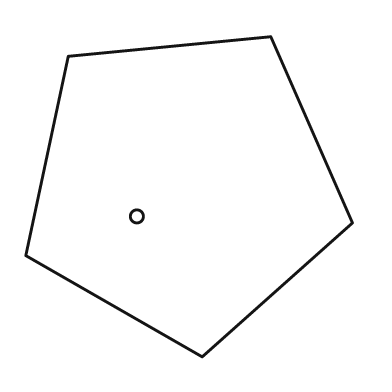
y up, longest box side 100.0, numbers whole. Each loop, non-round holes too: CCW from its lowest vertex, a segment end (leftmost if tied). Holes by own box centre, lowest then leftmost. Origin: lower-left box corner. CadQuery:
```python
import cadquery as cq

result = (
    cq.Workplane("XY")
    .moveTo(54.0, 0.0)
    .lineTo(100.0, 41.0)
    .lineTo(75.0, 98.0)
    .lineTo(13.0, 92.0)
    .lineTo(0.0, 31.0)
    .close()
    .moveTo(34.0, 43.0)
    .circle(2.0)
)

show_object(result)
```